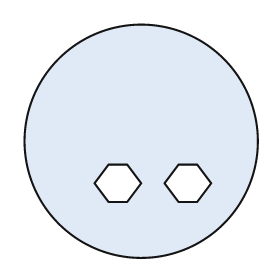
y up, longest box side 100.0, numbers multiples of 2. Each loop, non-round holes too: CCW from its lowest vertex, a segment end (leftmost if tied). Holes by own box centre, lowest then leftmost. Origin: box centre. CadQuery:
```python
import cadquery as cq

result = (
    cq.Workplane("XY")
    .moveTo(0.0, 0.0)
    .circle(50.0)
    .moveTo(-14.0, -26.0)
    .lineTo(-6.0, -26.0)
    .lineTo(0.0, -18.0)
    .lineTo(-6.0, -10.0)
    .lineTo(-14.0, -10.0)
    .lineTo(-20.0, -18.0)
    .close()
    .moveTo(16.0, -26.0)
    .lineTo(24.0, -26.0)
    .lineTo(30.0, -18.0)
    .lineTo(24.0, -10.0)
    .lineTo(16.0, -10.0)
    .lineTo(10.0, -18.0)
    .close()
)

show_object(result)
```